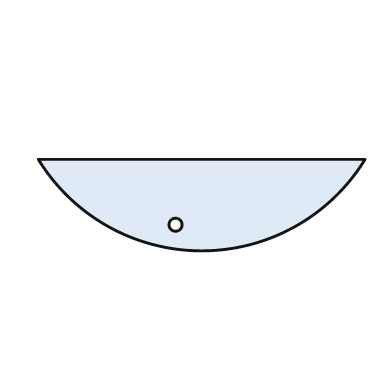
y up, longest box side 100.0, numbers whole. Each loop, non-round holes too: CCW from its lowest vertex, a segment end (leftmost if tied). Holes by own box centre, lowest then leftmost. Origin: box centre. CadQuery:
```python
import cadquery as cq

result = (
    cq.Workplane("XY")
    .moveTo(-50.0, 14.0)
    .threePointArc((0.0, -14.0), (50.0, 14.0))
    .close()
    .moveTo(-8.0, -6.0)
    .circle(2.0)
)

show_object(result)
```